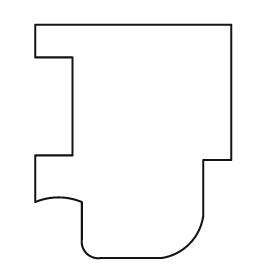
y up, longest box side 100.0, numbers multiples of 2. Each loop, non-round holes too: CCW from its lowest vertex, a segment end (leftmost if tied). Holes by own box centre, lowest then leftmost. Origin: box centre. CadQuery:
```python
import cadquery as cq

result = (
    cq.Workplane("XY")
    .moveTo(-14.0, -50.0)
    .lineTo(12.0, -50.0)
    .threePointArc((24.0, -44.0), (30.0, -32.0))
    .lineTo(30.0, -8.0)
    .lineTo(42.0, -8.0)
    .lineTo(42.0, 50.0)
    .lineTo(-42.0, 50.0)
    .lineTo(-42.0, 36.0)
    .lineTo(-26.0, 36.0)
    .lineTo(-26.0, -6.0)
    .lineTo(-42.0, -6.0)
    .lineTo(-42.0, -26.0)
    .threePointArc((-32.0, -24.0), (-22.0, -26.0))
    .lineTo(-22.0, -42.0)
    .threePointArc((-20.0, -48.0), (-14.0, -50.0))
    .close()
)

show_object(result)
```